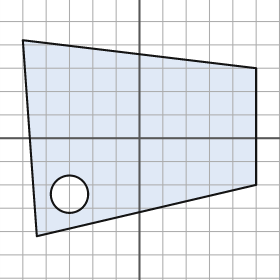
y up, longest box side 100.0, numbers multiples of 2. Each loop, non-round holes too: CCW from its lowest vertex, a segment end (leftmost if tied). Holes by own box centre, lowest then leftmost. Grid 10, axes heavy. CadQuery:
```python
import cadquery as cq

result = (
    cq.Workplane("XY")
    .moveTo(-44.0, -42.0)
    .lineTo(50.0, -20.0)
    .lineTo(50.0, 30.0)
    .lineTo(-50.0, 42.0)
    .close()
    .moveTo(-30.0, -24.0)
    .circle(8.0)
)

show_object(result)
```